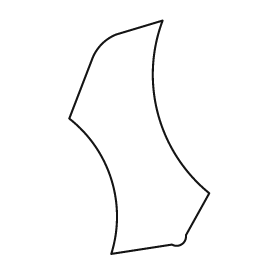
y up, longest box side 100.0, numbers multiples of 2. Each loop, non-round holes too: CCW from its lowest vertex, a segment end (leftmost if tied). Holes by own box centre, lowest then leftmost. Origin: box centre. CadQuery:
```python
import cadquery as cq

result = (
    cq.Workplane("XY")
    .moveTo(-12.0, -50.0)
    .lineTo(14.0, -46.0)
    .threePointArc((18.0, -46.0), (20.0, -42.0))
    .lineTo(30.0, -24.0)
    .threePointArc((8.0, 10.0), (10.0, 50.0))
    .lineTo(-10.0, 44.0)
    .threePointArc((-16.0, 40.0), (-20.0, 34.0))
    .lineTo(-30.0, 8.0)
    .threePointArc((-12.0, -18.0), (-12.0, -50.0))
    .close()
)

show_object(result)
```